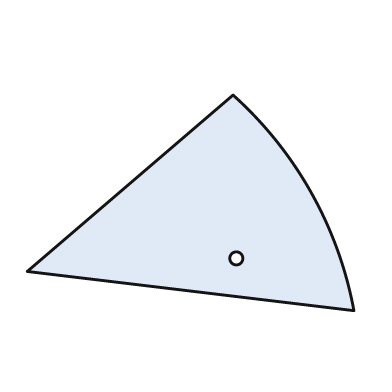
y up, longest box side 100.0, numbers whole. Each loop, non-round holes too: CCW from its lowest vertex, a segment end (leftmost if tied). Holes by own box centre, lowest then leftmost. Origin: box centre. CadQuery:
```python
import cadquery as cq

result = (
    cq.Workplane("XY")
    .moveTo(50.0, -33.0)
    .threePointArc((37.0, 3.0), (13.0, 33.0))
    .lineTo(-50.0, -21.0)
    .close()
    .moveTo(14.0, -17.0)
    .circle(2.0)
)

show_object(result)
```